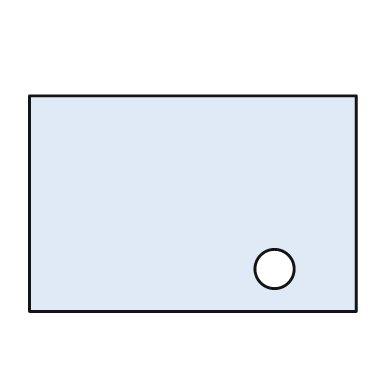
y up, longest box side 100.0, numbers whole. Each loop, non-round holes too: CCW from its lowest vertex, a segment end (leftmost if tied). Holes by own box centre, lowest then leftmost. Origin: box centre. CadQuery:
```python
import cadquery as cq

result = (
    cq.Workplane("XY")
    .moveTo(-50.0, -33.0)
    .lineTo(50.0, -33.0)
    .lineTo(50.0, 33.0)
    .lineTo(-50.0, 33.0)
    .close()
    .moveTo(25.0, -20.0)
    .circle(6.0)
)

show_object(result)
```